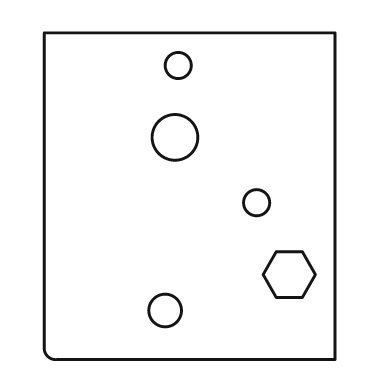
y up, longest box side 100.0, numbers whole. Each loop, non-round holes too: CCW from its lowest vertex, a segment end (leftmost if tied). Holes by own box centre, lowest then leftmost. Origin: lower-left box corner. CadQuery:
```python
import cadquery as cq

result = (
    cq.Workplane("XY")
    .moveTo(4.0, 0.0)
    .lineTo(89.0, 0.0)
    .lineTo(89.0, 100.0)
    .lineTo(0.0, 100.0)
    .lineTo(0.0, 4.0)
    .threePointArc((1.0, 1.0), (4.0, 0.0))
    .close()
    .moveTo(37.0, 15.0)
    .circle(5.0)
    .moveTo(71.0, 19.0)
    .lineTo(79.0, 19.0)
    .lineTo(83.0, 26.0)
    .lineTo(79.0, 33.0)
    .lineTo(71.0, 33.0)
    .lineTo(67.0, 26.0)
    .close()
    .moveTo(65.0, 48.0)
    .circle(4.0)
    .moveTo(40.0, 68.0)
    .circle(7.0)
    .moveTo(41.0, 90.0)
    .circle(4.0)
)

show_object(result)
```